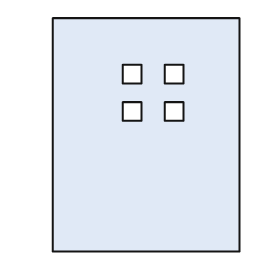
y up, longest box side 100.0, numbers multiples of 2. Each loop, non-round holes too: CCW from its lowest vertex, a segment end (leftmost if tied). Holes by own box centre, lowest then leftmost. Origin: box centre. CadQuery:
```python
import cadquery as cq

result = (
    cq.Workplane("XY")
    .moveTo(-40.0, -50.0)
    .lineTo(40.0, -50.0)
    .lineTo(40.0, 50.0)
    .lineTo(-40.0, 50.0)
    .close()
    .moveTo(-10.0, 6.0)
    .lineTo(-2.0, 6.0)
    .lineTo(-2.0, 14.0)
    .lineTo(-10.0, 14.0)
    .close()
    .moveTo(8.0, 6.0)
    .lineTo(16.0, 6.0)
    .lineTo(16.0, 14.0)
    .lineTo(8.0, 14.0)
    .close()
    .moveTo(-10.0, 22.0)
    .lineTo(-2.0, 22.0)
    .lineTo(-2.0, 30.0)
    .lineTo(-10.0, 30.0)
    .close()
    .moveTo(8.0, 22.0)
    .lineTo(16.0, 22.0)
    .lineTo(16.0, 30.0)
    .lineTo(8.0, 30.0)
    .close()
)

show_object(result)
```